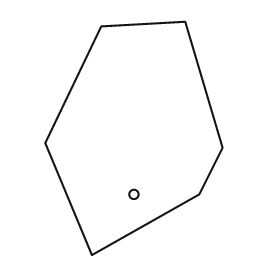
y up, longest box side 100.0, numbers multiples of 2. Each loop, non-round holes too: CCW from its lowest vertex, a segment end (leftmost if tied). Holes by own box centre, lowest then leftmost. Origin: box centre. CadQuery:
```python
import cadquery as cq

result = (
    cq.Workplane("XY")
    .moveTo(-18.0, -50.0)
    .lineTo(28.0, -24.0)
    .lineTo(38.0, -4.0)
    .lineTo(22.0, 50.0)
    .lineTo(-14.0, 48.0)
    .lineTo(-38.0, -2.0)
    .close()
    .moveTo(0.0, -24.0)
    .circle(2.0)
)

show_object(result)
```